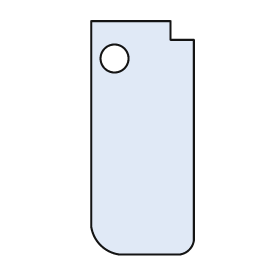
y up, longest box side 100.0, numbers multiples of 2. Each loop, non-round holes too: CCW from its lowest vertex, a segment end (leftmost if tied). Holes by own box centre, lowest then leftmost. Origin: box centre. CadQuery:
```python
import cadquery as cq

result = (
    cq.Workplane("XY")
    .moveTo(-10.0, -50.0)
    .lineTo(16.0, -50.0)
    .threePointArc((20.0, -48.0), (22.0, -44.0))
    .lineTo(22.0, 42.0)
    .lineTo(12.0, 42.0)
    .lineTo(12.0, 50.0)
    .lineTo(-22.0, 50.0)
    .lineTo(-22.0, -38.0)
    .threePointArc((-18.0, -46.0), (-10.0, -50.0))
    .close()
    .moveTo(-12.0, 34.0)
    .circle(6.0)
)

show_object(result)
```